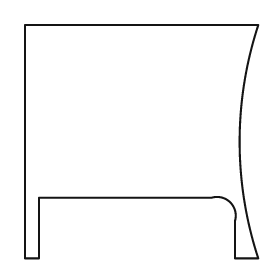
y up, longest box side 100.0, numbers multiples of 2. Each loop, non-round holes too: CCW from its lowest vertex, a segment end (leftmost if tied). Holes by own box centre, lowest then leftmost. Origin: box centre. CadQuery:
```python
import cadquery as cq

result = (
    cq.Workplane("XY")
    .moveTo(-50.0, -50.0)
    .lineTo(-44.0, -50.0)
    .lineTo(-44.0, -24.0)
    .lineTo(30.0, -24.0)
    .threePointArc((38.0, -26.0), (40.0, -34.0))
    .lineTo(40.0, -50.0)
    .lineTo(50.0, -50.0)
    .threePointArc((42.0, 0.0), (50.0, 50.0))
    .lineTo(-50.0, 50.0)
    .close()
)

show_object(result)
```